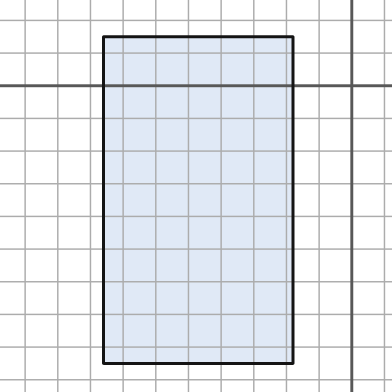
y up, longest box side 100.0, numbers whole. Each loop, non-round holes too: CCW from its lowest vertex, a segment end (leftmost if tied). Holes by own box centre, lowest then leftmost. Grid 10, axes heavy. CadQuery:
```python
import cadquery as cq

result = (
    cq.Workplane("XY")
    .moveTo(-76.0, -85.0)
    .lineTo(-18.0, -85.0)
    .lineTo(-18.0, 15.0)
    .lineTo(-76.0, 15.0)
    .close()
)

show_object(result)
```